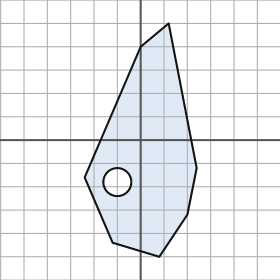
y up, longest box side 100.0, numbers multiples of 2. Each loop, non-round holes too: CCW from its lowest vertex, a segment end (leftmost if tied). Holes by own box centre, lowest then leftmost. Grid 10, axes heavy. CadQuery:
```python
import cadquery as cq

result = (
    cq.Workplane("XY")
    .moveTo(8.0, -50.0)
    .lineTo(20.0, -32.0)
    .lineTo(24.0, -12.0)
    .lineTo(12.0, 50.0)
    .lineTo(0.0, 40.0)
    .lineTo(-24.0, -16.0)
    .lineTo(-12.0, -44.0)
    .close()
    .moveTo(-10.0, -18.0)
    .circle(6.0)
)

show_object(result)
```